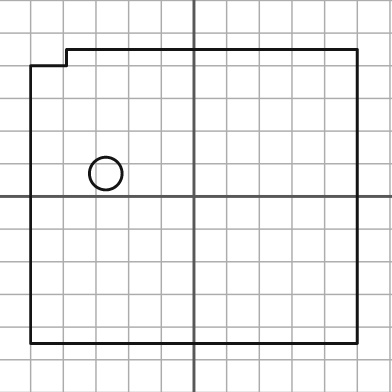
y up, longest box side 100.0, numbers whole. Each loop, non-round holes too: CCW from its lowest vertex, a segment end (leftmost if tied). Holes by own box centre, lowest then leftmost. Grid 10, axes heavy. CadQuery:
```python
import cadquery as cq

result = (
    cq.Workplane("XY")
    .moveTo(-50.0, -45.0)
    .lineTo(50.0, -45.0)
    .lineTo(50.0, 45.0)
    .lineTo(-39.0, 45.0)
    .lineTo(-39.0, 40.0)
    .lineTo(-50.0, 40.0)
    .close()
    .moveTo(-27.0, 7.0)
    .circle(5.0)
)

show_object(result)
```